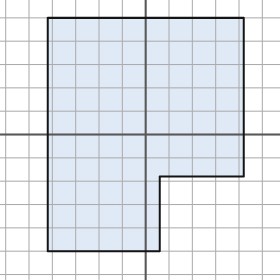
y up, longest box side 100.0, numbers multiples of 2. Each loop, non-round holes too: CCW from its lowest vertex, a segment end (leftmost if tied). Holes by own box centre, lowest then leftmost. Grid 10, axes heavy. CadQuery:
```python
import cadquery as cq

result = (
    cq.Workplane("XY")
    .moveTo(-42.0, -50.0)
    .lineTo(6.0, -50.0)
    .lineTo(6.0, -18.0)
    .lineTo(42.0, -18.0)
    .lineTo(42.0, 50.0)
    .lineTo(-42.0, 50.0)
    .close()
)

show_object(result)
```